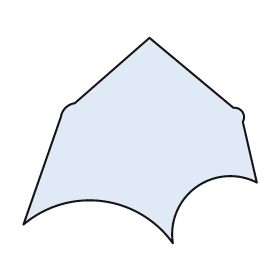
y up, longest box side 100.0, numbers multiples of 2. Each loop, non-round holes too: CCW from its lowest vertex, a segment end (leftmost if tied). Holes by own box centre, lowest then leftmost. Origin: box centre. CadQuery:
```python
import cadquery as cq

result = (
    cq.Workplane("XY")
    .moveTo(14.0, -44.0)
    .threePointArc((24.0, -20.0), (50.0, -18.0))
    .lineTo(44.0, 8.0)
    .threePointArc((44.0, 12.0), (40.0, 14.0))
    .lineTo(4.0, 44.0)
    .lineTo(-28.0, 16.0)
    .threePointArc((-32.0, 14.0), (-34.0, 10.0))
    .lineTo(-50.0, -36.0)
    .threePointArc((-16.0, -26.0), (14.0, -44.0))
    .close()
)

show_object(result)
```